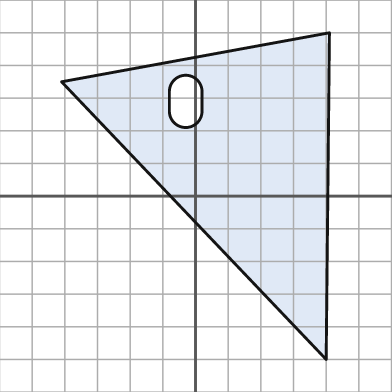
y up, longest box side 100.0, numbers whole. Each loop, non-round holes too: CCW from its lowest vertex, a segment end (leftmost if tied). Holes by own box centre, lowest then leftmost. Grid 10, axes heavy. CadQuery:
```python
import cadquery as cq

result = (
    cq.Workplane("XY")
    .moveTo(40.0, -50.0)
    .lineTo(41.0, 50.0)
    .lineTo(-41.0, 35.0)
    .close()
    .moveTo(-8.0, 26.0)
    .threePointArc((-3.0, 21.0), (2.0, 26.0))
    .lineTo(2.0, 32.0)
    .threePointArc((-3.0, 37.0), (-8.0, 32.0))
    .close()
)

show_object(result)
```